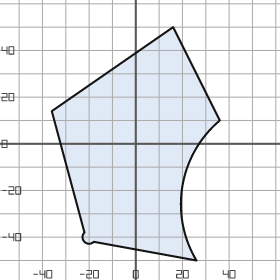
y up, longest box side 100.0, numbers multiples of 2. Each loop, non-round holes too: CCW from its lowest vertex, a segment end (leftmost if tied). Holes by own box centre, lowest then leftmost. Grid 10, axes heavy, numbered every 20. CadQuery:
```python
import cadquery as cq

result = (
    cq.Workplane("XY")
    .moveTo(26.0, -50.0)
    .threePointArc((20.0, -18.0), (36.0, 10.0))
    .lineTo(16.0, 50.0)
    .lineTo(-36.0, 14.0)
    .lineTo(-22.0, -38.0)
    .threePointArc((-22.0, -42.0), (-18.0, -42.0))
    .close()
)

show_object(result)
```